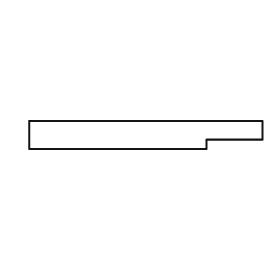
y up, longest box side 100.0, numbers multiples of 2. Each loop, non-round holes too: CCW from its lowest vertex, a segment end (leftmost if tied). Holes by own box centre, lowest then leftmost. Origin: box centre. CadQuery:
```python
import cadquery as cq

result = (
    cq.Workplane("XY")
    .moveTo(-50.0, -6.0)
    .lineTo(26.0, -6.0)
    .lineTo(26.0, -2.0)
    .lineTo(50.0, -2.0)
    .lineTo(50.0, 6.0)
    .lineTo(-50.0, 6.0)
    .close()
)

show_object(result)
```